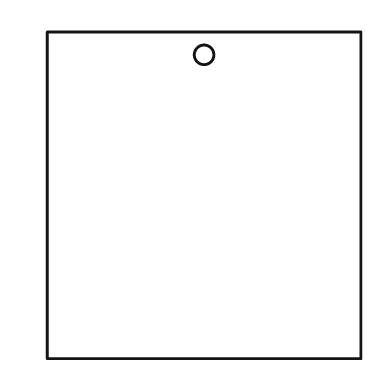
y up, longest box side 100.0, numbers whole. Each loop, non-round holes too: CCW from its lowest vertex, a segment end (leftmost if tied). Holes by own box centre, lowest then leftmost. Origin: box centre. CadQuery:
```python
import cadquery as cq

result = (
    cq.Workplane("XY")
    .moveTo(-48.0, -50.0)
    .lineTo(48.0, -50.0)
    .lineTo(48.0, 50.0)
    .lineTo(-48.0, 50.0)
    .close()
    .moveTo(0.0, 43.0)
    .circle(3.0)
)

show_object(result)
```